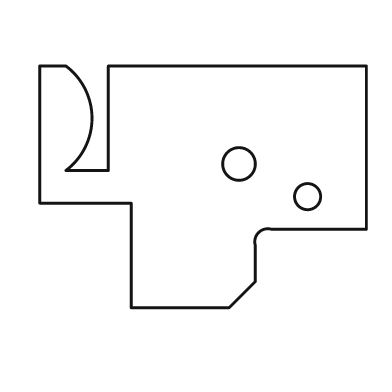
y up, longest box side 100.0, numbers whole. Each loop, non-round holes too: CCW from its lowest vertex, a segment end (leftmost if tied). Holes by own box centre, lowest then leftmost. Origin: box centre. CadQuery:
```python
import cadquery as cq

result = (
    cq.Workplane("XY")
    .moveTo(-22.0, -37.0)
    .lineTo(8.0, -37.0)
    .lineTo(16.0, -29.0)
    .lineTo(16.0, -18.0)
    .threePointArc((17.0, -14.0), (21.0, -13.0))
    .lineTo(50.0, -13.0)
    .lineTo(50.0, 37.0)
    .lineTo(-29.0, 37.0)
    .lineTo(-29.0, 5.0)
    .lineTo(-42.0, 5.0)
    .threePointArc((-34.0, 21.0), (-42.0, 37.0))
    .lineTo(-50.0, 37.0)
    .lineTo(-50.0, -5.0)
    .lineTo(-22.0, -5.0)
    .close()
    .moveTo(32.0, -3.0)
    .circle(4.0)
    .moveTo(11.0, 7.0)
    .circle(5.0)
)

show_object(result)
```